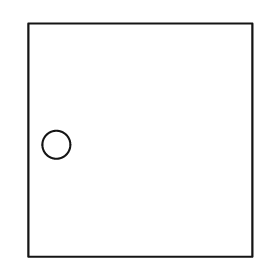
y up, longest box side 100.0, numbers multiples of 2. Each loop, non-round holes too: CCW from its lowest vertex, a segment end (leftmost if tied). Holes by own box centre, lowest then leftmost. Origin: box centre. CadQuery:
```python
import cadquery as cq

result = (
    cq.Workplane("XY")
    .moveTo(-48.0, -50.0)
    .lineTo(48.0, -50.0)
    .lineTo(48.0, 50.0)
    .lineTo(-48.0, 50.0)
    .close()
    .moveTo(-36.0, -2.0)
    .circle(6.0)
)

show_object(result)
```